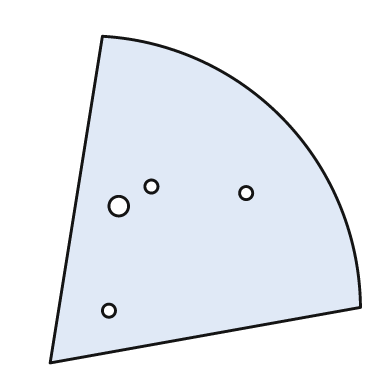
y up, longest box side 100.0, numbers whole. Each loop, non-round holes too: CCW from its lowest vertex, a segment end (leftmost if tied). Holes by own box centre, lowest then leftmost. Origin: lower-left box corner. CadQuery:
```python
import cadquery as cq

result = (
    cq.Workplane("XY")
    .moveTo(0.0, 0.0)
    .lineTo(95.0, 17.0)
    .threePointArc((72.0, 74.0), (16.0, 100.0))
    .close()
    .moveTo(18.0, 16.0)
    .circle(2.0)
    .moveTo(21.0, 48.0)
    .circle(3.0)
    .moveTo(60.0, 52.0)
    .circle(2.0)
    .moveTo(31.0, 54.0)
    .circle(2.0)
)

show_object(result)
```